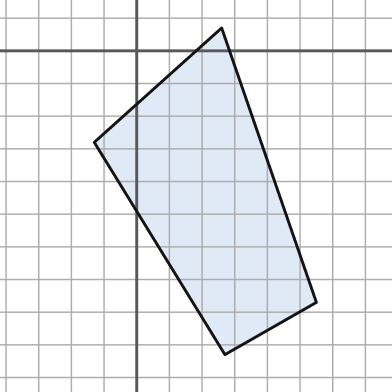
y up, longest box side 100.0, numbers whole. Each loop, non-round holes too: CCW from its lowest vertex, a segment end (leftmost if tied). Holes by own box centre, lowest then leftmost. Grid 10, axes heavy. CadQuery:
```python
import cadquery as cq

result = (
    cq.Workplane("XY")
    .moveTo(27.0, -93.0)
    .lineTo(55.0, -77.0)
    .lineTo(26.0, 7.0)
    .lineTo(-13.0, -28.0)
    .close()
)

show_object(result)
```